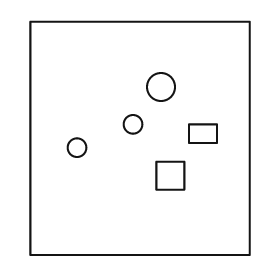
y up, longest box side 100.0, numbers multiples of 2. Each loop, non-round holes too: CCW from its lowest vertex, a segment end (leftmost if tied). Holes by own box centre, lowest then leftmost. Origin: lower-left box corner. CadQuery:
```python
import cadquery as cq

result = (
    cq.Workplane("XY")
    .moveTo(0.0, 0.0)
    .lineTo(94.0, 0.0)
    .lineTo(94.0, 100.0)
    .lineTo(0.0, 100.0)
    .close()
    .moveTo(54.0, 28.0)
    .lineTo(66.0, 28.0)
    .lineTo(66.0, 40.0)
    .lineTo(54.0, 40.0)
    .close()
    .moveTo(20.0, 46.0)
    .circle(4.0)
    .moveTo(68.0, 48.0)
    .lineTo(80.0, 48.0)
    .lineTo(80.0, 56.0)
    .lineTo(68.0, 56.0)
    .close()
    .moveTo(44.0, 56.0)
    .circle(4.0)
    .moveTo(56.0, 72.0)
    .circle(6.0)
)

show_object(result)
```